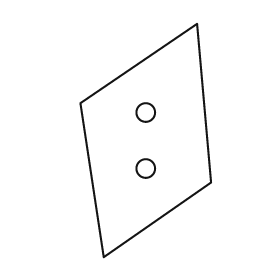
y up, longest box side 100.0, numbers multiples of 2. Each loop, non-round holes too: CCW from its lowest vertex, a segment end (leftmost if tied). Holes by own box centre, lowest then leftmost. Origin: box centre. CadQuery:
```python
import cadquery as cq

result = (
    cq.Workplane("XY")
    .moveTo(-18.0, -50.0)
    .lineTo(28.0, -18.0)
    .lineTo(22.0, 50.0)
    .lineTo(-28.0, 16.0)
    .close()
    .moveTo(0.0, -12.0)
    .circle(4.0)
    .moveTo(0.0, 12.0)
    .circle(4.0)
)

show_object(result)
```